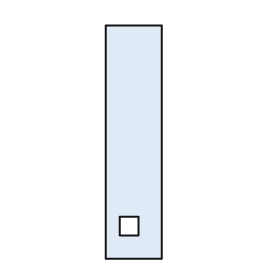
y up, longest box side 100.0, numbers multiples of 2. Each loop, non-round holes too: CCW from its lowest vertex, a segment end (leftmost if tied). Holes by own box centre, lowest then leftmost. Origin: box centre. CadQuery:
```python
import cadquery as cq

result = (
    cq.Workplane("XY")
    .moveTo(-12.0, -50.0)
    .lineTo(12.0, -50.0)
    .lineTo(12.0, 50.0)
    .lineTo(-12.0, 50.0)
    .close()
    .moveTo(-6.0, -40.0)
    .lineTo(2.0, -40.0)
    .lineTo(2.0, -32.0)
    .lineTo(-6.0, -32.0)
    .close()
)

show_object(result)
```